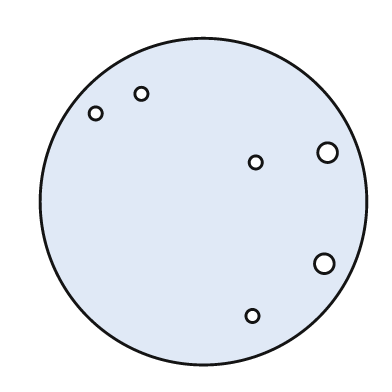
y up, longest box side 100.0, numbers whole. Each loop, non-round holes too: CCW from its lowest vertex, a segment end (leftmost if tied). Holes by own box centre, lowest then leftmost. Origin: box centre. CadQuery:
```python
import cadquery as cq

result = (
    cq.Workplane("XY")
    .moveTo(0.0, 0.0)
    .circle(50.0)
    .moveTo(15.0, -35.0)
    .circle(2.0)
    .moveTo(37.0, -19.0)
    .circle(3.0)
    .moveTo(16.0, 12.0)
    .circle(2.0)
    .moveTo(38.0, 15.0)
    .circle(3.0)
    .moveTo(-33.0, 27.0)
    .circle(2.0)
    .moveTo(-19.0, 33.0)
    .circle(2.0)
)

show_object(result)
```